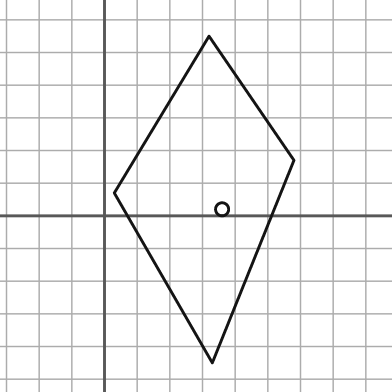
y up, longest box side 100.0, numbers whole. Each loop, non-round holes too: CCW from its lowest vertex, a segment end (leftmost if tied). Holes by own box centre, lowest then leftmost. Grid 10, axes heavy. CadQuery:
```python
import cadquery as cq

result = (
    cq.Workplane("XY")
    .moveTo(33.0, -45.0)
    .lineTo(58.0, 17.0)
    .lineTo(32.0, 55.0)
    .lineTo(3.0, 7.0)
    .close()
    .moveTo(36.0, 2.0)
    .circle(2.0)
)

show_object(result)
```